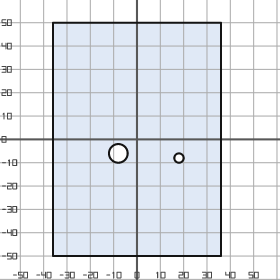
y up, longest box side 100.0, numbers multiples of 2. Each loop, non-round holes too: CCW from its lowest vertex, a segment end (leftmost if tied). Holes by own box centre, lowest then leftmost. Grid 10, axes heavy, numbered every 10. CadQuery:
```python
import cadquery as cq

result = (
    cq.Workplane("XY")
    .moveTo(-36.0, -50.0)
    .lineTo(36.0, -50.0)
    .lineTo(36.0, 50.0)
    .lineTo(-36.0, 50.0)
    .close()
    .moveTo(18.0, -8.0)
    .circle(2.0)
    .moveTo(-8.0, -6.0)
    .circle(4.0)
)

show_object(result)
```